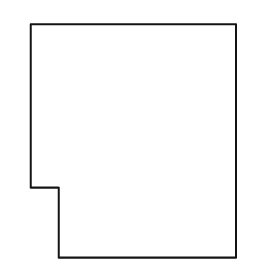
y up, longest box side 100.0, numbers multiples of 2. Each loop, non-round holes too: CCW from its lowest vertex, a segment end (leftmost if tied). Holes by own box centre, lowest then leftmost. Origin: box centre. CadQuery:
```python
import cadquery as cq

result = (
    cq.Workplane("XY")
    .moveTo(-32.0, -50.0)
    .lineTo(44.0, -50.0)
    .lineTo(44.0, 50.0)
    .lineTo(-44.0, 50.0)
    .lineTo(-44.0, -20.0)
    .lineTo(-32.0, -20.0)
    .close()
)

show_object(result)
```